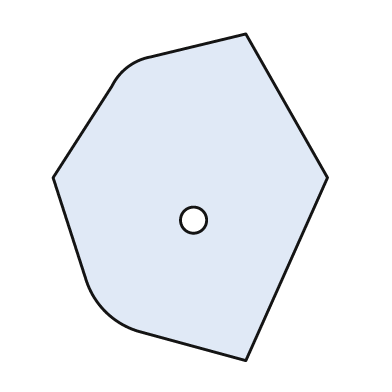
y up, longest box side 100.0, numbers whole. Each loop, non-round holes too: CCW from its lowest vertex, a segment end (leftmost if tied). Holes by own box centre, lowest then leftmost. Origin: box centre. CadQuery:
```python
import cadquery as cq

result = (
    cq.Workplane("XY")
    .moveTo(17.0, -50.0)
    .lineTo(42.0, 6.0)
    .lineTo(17.0, 50.0)
    .lineTo(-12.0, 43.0)
    .threePointArc((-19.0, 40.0), (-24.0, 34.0))
    .lineTo(-42.0, 6.0)
    .lineTo(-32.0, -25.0)
    .threePointArc((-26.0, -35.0), (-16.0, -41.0))
    .close()
    .moveTo(1.0, -7.0)
    .circle(4.0)
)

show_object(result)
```